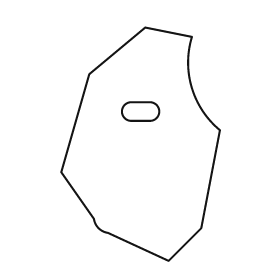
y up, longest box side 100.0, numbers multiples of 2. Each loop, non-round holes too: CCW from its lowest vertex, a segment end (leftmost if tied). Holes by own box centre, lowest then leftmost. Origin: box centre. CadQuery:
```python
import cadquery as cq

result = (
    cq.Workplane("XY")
    .moveTo(12.0, -50.0)
    .lineTo(26.0, -36.0)
    .lineTo(34.0, 6.0)
    .threePointArc((22.0, 24.0), (22.0, 46.0))
    .lineTo(2.0, 50.0)
    .lineTo(-22.0, 30.0)
    .lineTo(-34.0, -12.0)
    .lineTo(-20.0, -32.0)
    .threePointArc((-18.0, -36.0), (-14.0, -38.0))
    .close()
    .moveTo(-4.0, 10.0)
    .lineTo(4.0, 10.0)
    .threePointArc((8.0, 14.0), (4.0, 18.0))
    .lineTo(-4.0, 18.0)
    .threePointArc((-8.0, 14.0), (-4.0, 10.0))
    .close()
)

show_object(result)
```